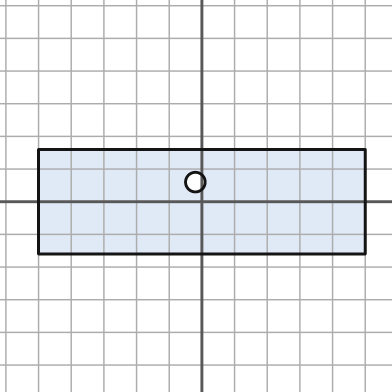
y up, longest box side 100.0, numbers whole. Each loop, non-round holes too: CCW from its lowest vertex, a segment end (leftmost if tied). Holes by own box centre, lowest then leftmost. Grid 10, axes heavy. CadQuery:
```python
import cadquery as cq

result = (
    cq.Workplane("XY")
    .moveTo(-50.0, -16.0)
    .lineTo(50.0, -16.0)
    .lineTo(50.0, 16.0)
    .lineTo(-50.0, 16.0)
    .close()
    .moveTo(-2.0, 6.0)
    .circle(3.0)
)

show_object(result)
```